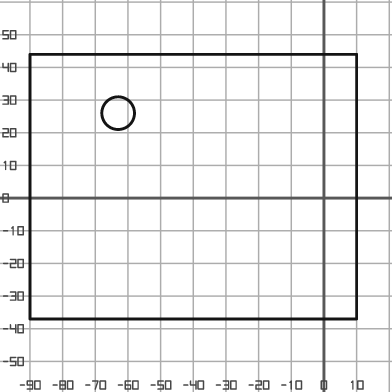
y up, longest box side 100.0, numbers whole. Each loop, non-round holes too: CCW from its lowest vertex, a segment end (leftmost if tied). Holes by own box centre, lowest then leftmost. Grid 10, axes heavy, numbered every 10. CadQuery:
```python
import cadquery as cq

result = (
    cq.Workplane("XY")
    .moveTo(-90.0, -37.0)
    .lineTo(10.0, -37.0)
    .lineTo(10.0, 44.0)
    .lineTo(-90.0, 44.0)
    .close()
    .moveTo(-63.0, 26.0)
    .circle(5.0)
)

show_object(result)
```